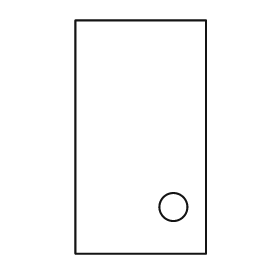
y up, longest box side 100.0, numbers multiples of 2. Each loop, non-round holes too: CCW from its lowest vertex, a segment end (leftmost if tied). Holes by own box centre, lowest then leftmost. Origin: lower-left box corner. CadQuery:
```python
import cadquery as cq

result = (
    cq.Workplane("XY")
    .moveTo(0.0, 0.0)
    .lineTo(56.0, 0.0)
    .lineTo(56.0, 100.0)
    .lineTo(0.0, 100.0)
    .close()
    .moveTo(42.0, 20.0)
    .circle(6.0)
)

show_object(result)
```